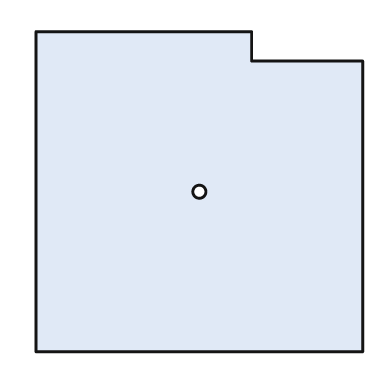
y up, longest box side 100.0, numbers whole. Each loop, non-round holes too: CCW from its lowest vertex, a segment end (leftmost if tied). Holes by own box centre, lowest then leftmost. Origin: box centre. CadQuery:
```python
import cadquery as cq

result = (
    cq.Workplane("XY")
    .moveTo(-50.0, -49.0)
    .lineTo(50.0, -49.0)
    .lineTo(50.0, 40.0)
    .lineTo(16.0, 40.0)
    .lineTo(16.0, 49.0)
    .lineTo(-50.0, 49.0)
    .close()
    .moveTo(0.0, 0.0)
    .circle(2.0)
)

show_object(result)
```